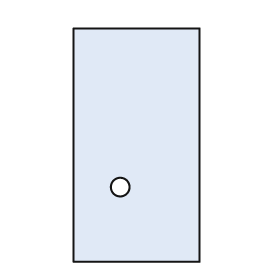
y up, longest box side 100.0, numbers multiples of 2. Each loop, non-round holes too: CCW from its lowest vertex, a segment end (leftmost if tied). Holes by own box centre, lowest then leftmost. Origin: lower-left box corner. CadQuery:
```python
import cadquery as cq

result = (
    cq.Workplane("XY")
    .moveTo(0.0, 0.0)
    .lineTo(54.0, 0.0)
    .lineTo(54.0, 100.0)
    .lineTo(0.0, 100.0)
    .close()
    .moveTo(20.0, 32.0)
    .circle(4.0)
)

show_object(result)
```